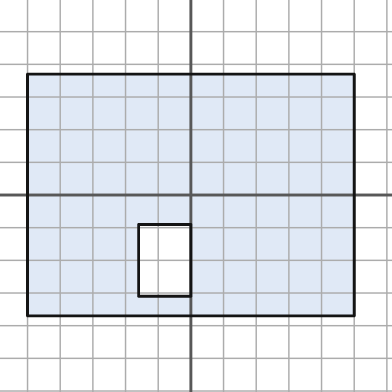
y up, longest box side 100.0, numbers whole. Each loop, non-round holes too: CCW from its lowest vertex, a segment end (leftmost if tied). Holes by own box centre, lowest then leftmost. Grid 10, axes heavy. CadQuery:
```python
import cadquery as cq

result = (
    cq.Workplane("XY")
    .moveTo(-50.0, -37.0)
    .lineTo(50.0, -37.0)
    .lineTo(50.0, 37.0)
    .lineTo(-50.0, 37.0)
    .close()
    .moveTo(-16.0, -31.0)
    .lineTo(0.0, -31.0)
    .lineTo(0.0, -9.0)
    .lineTo(-16.0, -9.0)
    .close()
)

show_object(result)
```